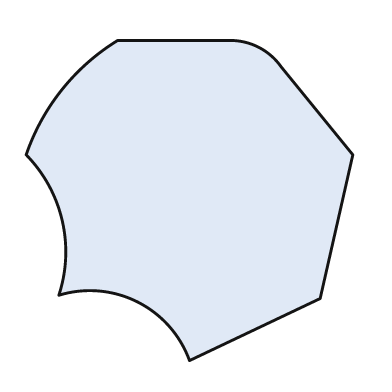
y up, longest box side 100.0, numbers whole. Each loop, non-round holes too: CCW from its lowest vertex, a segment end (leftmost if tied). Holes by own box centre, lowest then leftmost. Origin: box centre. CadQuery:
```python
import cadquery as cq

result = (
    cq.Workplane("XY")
    .moveTo(0.0, -49.0)
    .lineTo(40.0, -30.0)
    .lineTo(50.0, 14.0)
    .lineTo(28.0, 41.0)
    .threePointArc((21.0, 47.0), (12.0, 49.0))
    .lineTo(-22.0, 49.0)
    .threePointArc((-39.0, 34.0), (-50.0, 14.0))
    .threePointArc((-39.0, -6.0), (-40.0, -29.0))
    .threePointArc((-16.0, -31.0), (0.0, -49.0))
    .close()
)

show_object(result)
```